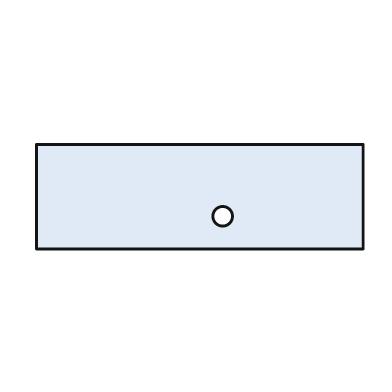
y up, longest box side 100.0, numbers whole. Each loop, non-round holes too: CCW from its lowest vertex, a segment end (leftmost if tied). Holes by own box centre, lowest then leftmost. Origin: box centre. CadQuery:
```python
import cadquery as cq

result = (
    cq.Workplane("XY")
    .moveTo(-50.0, -16.0)
    .lineTo(50.0, -16.0)
    .lineTo(50.0, 16.0)
    .lineTo(-50.0, 16.0)
    .close()
    .moveTo(7.0, -6.0)
    .circle(3.0)
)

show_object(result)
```